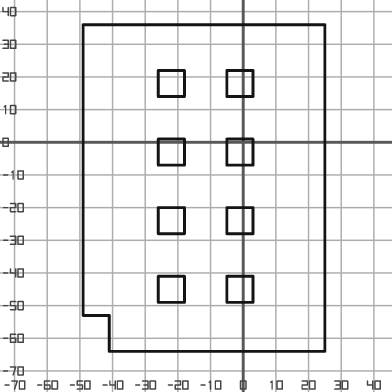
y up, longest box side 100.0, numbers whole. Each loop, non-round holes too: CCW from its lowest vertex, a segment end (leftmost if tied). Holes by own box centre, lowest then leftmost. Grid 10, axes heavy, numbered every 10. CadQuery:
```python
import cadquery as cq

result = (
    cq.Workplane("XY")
    .moveTo(-41.0, -64.0)
    .lineTo(25.0, -64.0)
    .lineTo(25.0, 36.0)
    .lineTo(-49.0, 36.0)
    .lineTo(-49.0, -53.0)
    .lineTo(-41.0, -53.0)
    .close()
    .moveTo(-26.0, -49.0)
    .lineTo(-18.0, -49.0)
    .lineTo(-18.0, -41.0)
    .lineTo(-26.0, -41.0)
    .close()
    .moveTo(-5.0, -49.0)
    .lineTo(3.0, -49.0)
    .lineTo(3.0, -41.0)
    .lineTo(-5.0, -41.0)
    .close()
    .moveTo(-26.0, -28.0)
    .lineTo(-18.0, -28.0)
    .lineTo(-18.0, -20.0)
    .lineTo(-26.0, -20.0)
    .close()
    .moveTo(-5.0, -28.0)
    .lineTo(3.0, -28.0)
    .lineTo(3.0, -20.0)
    .lineTo(-5.0, -20.0)
    .close()
    .moveTo(-26.0, -7.0)
    .lineTo(-18.0, -7.0)
    .lineTo(-18.0, 1.0)
    .lineTo(-26.0, 1.0)
    .close()
    .moveTo(-5.0, -7.0)
    .lineTo(3.0, -7.0)
    .lineTo(3.0, 1.0)
    .lineTo(-5.0, 1.0)
    .close()
    .moveTo(-26.0, 14.0)
    .lineTo(-18.0, 14.0)
    .lineTo(-18.0, 22.0)
    .lineTo(-26.0, 22.0)
    .close()
    .moveTo(-5.0, 14.0)
    .lineTo(3.0, 14.0)
    .lineTo(3.0, 22.0)
    .lineTo(-5.0, 22.0)
    .close()
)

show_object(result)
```